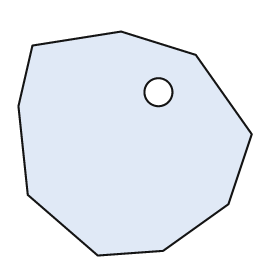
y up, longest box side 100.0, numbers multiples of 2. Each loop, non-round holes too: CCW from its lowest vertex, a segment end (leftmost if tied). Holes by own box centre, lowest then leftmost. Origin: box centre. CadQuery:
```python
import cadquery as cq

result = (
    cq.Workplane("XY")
    .moveTo(-16.0, -48.0)
    .lineTo(12.0, -46.0)
    .lineTo(40.0, -26.0)
    .lineTo(50.0, 4.0)
    .lineTo(26.0, 38.0)
    .lineTo(-6.0, 48.0)
    .lineTo(-44.0, 42.0)
    .lineTo(-50.0, 16.0)
    .lineTo(-46.0, -22.0)
    .close()
    .moveTo(10.0, 22.0)
    .circle(6.0)
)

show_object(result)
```